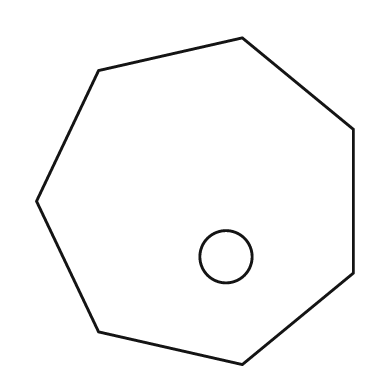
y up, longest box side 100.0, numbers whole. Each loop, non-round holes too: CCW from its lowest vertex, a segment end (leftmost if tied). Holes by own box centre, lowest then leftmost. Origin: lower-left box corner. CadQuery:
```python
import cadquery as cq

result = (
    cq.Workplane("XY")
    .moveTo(63.0, 0.0)
    .lineTo(97.0, 28.0)
    .lineTo(97.0, 72.0)
    .lineTo(63.0, 100.0)
    .lineTo(19.0, 90.0)
    .lineTo(0.0, 50.0)
    .lineTo(19.0, 10.0)
    .close()
    .moveTo(58.0, 33.0)
    .circle(8.0)
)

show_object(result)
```